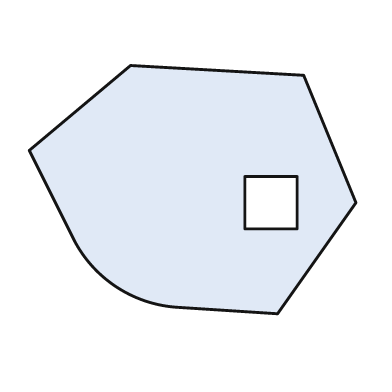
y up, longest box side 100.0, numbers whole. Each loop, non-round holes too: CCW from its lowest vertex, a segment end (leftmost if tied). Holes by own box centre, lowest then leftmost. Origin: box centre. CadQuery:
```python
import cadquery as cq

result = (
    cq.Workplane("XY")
    .moveTo(26.0, -38.0)
    .lineTo(50.0, -4.0)
    .lineTo(34.0, 35.0)
    .lineTo(-19.0, 38.0)
    .lineTo(-50.0, 12.0)
    .lineTo(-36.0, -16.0)
    .threePointArc((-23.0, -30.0), (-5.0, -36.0))
    .close()
    .moveTo(16.0, -12.0)
    .lineTo(32.0, -12.0)
    .lineTo(32.0, 4.0)
    .lineTo(16.0, 4.0)
    .close()
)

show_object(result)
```